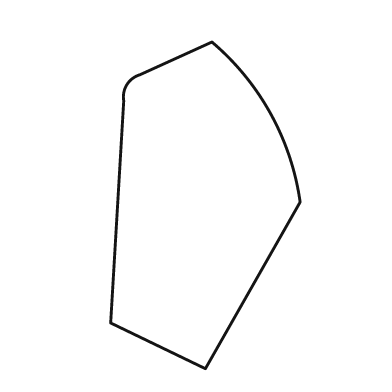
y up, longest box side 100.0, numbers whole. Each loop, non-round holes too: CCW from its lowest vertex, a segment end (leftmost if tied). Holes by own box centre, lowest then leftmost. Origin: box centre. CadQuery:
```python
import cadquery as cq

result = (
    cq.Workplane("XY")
    .moveTo(0.0, -50.0)
    .lineTo(29.0, 1.0)
    .threePointArc((20.0, 28.0), (2.0, 50.0))
    .lineTo(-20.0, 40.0)
    .threePointArc((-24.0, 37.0), (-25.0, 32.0))
    .lineTo(-29.0, -36.0)
    .close()
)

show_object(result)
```